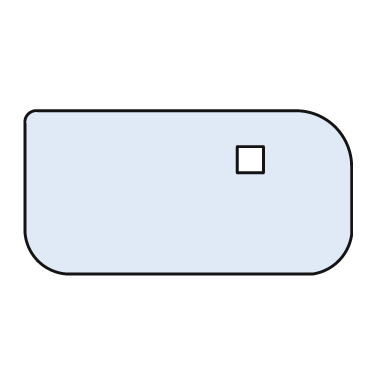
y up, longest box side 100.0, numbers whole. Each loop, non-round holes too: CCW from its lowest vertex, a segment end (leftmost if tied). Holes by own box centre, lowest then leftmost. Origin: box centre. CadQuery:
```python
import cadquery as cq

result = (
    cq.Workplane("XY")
    .moveTo(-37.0, -25.0)
    .lineTo(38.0, -25.0)
    .threePointArc((46.0, -21.0), (50.0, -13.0))
    .lineTo(50.0, 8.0)
    .threePointArc((45.0, 20.0), (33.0, 25.0))
    .lineTo(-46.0, 25.0)
    .threePointArc((-49.0, 24.0), (-50.0, 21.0))
    .lineTo(-50.0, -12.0)
    .threePointArc((-46.0, -21.0), (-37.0, -25.0))
    .close()
    .moveTo(15.0, 6.0)
    .lineTo(23.0, 6.0)
    .lineTo(23.0, 14.0)
    .lineTo(15.0, 14.0)
    .close()
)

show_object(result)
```